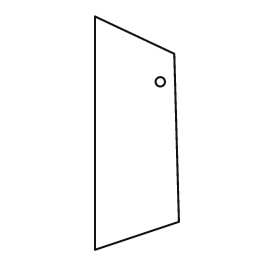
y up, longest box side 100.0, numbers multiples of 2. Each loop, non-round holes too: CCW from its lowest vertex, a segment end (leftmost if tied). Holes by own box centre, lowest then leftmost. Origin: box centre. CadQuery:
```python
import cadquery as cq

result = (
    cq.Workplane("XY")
    .moveTo(-18.0, -50.0)
    .lineTo(18.0, -38.0)
    .lineTo(16.0, 34.0)
    .lineTo(-18.0, 50.0)
    .close()
    .moveTo(10.0, 22.0)
    .circle(2.0)
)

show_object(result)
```